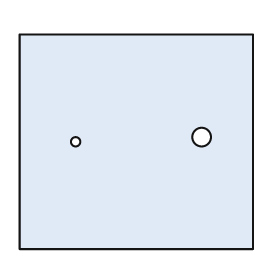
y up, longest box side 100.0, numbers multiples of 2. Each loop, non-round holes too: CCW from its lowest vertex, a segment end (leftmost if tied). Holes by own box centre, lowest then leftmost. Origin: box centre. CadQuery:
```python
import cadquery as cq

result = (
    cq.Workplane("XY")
    .moveTo(-50.0, -46.0)
    .lineTo(50.0, -46.0)
    .lineTo(50.0, 46.0)
    .lineTo(-50.0, 46.0)
    .close()
    .moveTo(-26.0, 0.0)
    .circle(2.0)
    .moveTo(28.0, 2.0)
    .circle(4.0)
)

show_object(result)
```